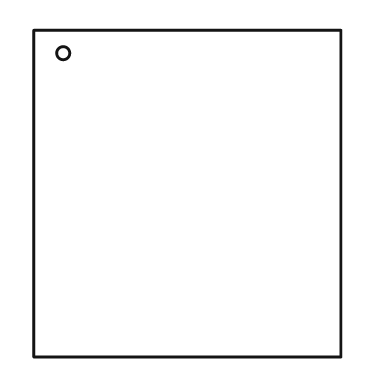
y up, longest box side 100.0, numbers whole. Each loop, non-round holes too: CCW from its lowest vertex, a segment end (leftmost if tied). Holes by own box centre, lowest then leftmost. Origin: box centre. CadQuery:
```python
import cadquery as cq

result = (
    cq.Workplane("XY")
    .moveTo(-47.0, -50.0)
    .lineTo(47.0, -50.0)
    .lineTo(47.0, 50.0)
    .lineTo(-47.0, 50.0)
    .close()
    .moveTo(-38.0, 43.0)
    .circle(2.0)
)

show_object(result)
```